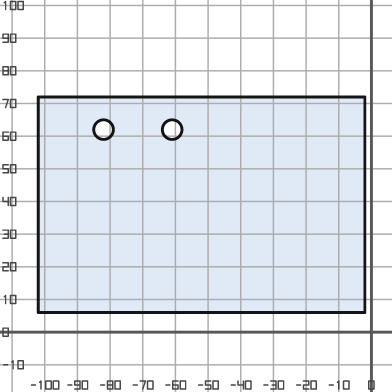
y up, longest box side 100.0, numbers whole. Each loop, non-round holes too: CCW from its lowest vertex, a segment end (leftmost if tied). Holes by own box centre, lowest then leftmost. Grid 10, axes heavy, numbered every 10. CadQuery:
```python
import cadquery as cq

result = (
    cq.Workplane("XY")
    .moveTo(-102.0, 6.0)
    .lineTo(-2.0, 6.0)
    .lineTo(-2.0, 72.0)
    .lineTo(-102.0, 72.0)
    .close()
    .moveTo(-82.0, 62.0)
    .circle(3.0)
    .moveTo(-61.0, 62.0)
    .circle(3.0)
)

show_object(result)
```